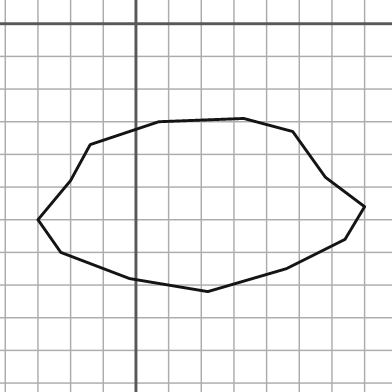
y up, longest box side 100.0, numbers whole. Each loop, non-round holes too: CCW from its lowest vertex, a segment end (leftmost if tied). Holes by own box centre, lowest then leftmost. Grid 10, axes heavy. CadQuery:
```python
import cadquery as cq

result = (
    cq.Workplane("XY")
    .moveTo(22.0, -82.0)
    .lineTo(46.0, -75.0)
    .lineTo(64.0, -66.0)
    .lineTo(70.0, -56.0)
    .lineTo(58.0, -47.0)
    .lineTo(48.0, -33.0)
    .lineTo(33.0, -29.0)
    .lineTo(7.0, -30.0)
    .lineTo(-14.0, -37.0)
    .lineTo(-20.0, -48.0)
    .lineTo(-30.0, -60.0)
    .lineTo(-23.0, -70.0)
    .lineTo(-2.0, -78.0)
    .close()
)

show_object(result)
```